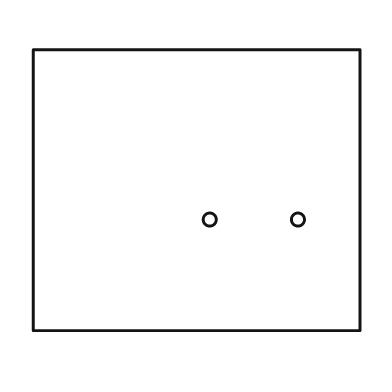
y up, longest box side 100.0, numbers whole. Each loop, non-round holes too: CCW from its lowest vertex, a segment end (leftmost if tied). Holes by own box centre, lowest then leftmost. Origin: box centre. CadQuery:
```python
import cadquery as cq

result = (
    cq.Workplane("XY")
    .moveTo(-50.0, -43.0)
    .lineTo(50.0, -43.0)
    .lineTo(50.0, 43.0)
    .lineTo(-50.0, 43.0)
    .close()
    .moveTo(4.0, -9.0)
    .circle(2.0)
    .moveTo(31.0, -9.0)
    .circle(2.0)
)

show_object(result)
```